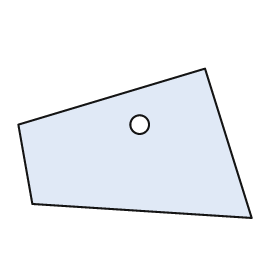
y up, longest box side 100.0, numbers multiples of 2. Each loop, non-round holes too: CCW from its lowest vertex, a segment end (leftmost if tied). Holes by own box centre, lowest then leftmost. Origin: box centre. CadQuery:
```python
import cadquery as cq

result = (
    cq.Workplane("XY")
    .moveTo(50.0, -32.0)
    .lineTo(30.0, 32.0)
    .lineTo(-50.0, 8.0)
    .lineTo(-44.0, -26.0)
    .close()
    .moveTo(2.0, 8.0)
    .circle(4.0)
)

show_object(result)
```